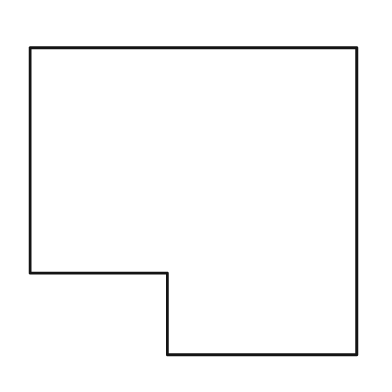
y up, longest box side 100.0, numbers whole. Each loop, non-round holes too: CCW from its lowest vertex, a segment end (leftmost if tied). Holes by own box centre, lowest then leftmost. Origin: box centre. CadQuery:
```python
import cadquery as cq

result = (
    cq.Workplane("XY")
    .moveTo(-8.0, -47.0)
    .lineTo(50.0, -47.0)
    .lineTo(50.0, 47.0)
    .lineTo(-50.0, 47.0)
    .lineTo(-50.0, -22.0)
    .lineTo(-8.0, -22.0)
    .close()
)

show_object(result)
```